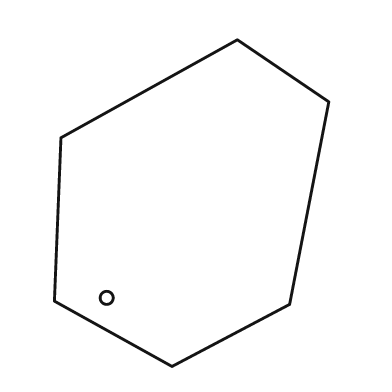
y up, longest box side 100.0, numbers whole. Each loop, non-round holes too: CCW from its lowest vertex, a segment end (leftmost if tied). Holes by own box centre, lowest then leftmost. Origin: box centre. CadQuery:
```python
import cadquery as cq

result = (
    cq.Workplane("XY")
    .moveTo(-6.0, -50.0)
    .lineTo(30.0, -31.0)
    .lineTo(42.0, 31.0)
    .lineTo(14.0, 50.0)
    .lineTo(-40.0, 20.0)
    .lineTo(-42.0, -30.0)
    .close()
    .moveTo(-26.0, -29.0)
    .circle(2.0)
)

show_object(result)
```